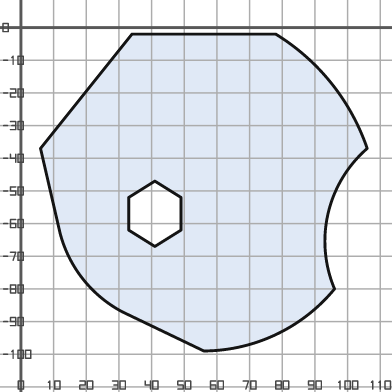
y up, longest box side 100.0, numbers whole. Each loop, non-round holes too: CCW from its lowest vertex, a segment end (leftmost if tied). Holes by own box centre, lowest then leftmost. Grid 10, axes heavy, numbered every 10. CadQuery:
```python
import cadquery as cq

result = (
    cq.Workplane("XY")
    .moveTo(56.0, -99.0)
    .threePointArc((78.0, -94.0), (96.0, -80.0))
    .threePointArc((94.0, -57.0), (106.0, -37.0))
    .threePointArc((95.0, -17.0), (78.0, -2.0))
    .lineTo(34.0, -2.0)
    .lineTo(6.0, -37.0)
    .lineTo(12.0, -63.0)
    .threePointArc((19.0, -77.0), (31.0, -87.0))
    .close()
    .moveTo(41.0, -67.0)
    .lineTo(49.0, -62.0)
    .lineTo(49.0, -52.0)
    .lineTo(41.0, -47.0)
    .lineTo(33.0, -52.0)
    .lineTo(33.0, -62.0)
    .close()
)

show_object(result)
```